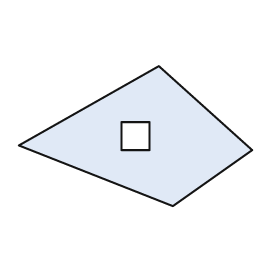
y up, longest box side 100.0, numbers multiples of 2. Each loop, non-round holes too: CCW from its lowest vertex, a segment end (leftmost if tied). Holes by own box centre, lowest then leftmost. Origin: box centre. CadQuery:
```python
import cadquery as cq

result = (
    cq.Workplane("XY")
    .moveTo(16.0, -30.0)
    .lineTo(50.0, -6.0)
    .lineTo(10.0, 30.0)
    .lineTo(-50.0, -4.0)
    .close()
    .moveTo(-6.0, -6.0)
    .lineTo(6.0, -6.0)
    .lineTo(6.0, 6.0)
    .lineTo(-6.0, 6.0)
    .close()
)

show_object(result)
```